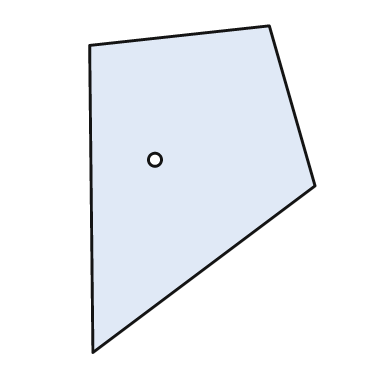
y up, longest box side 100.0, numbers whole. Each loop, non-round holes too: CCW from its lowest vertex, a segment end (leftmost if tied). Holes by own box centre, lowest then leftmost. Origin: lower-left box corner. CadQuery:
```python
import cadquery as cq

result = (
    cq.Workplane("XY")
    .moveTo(1.0, 0.0)
    .lineTo(69.0, 51.0)
    .lineTo(55.0, 100.0)
    .lineTo(0.0, 94.0)
    .close()
    .moveTo(20.0, 59.0)
    .circle(2.0)
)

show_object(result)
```